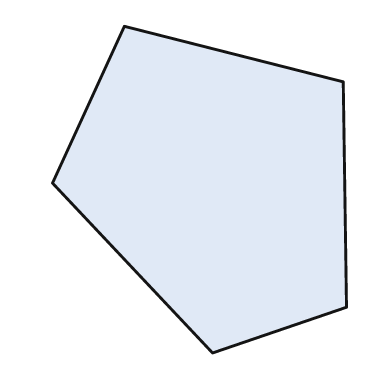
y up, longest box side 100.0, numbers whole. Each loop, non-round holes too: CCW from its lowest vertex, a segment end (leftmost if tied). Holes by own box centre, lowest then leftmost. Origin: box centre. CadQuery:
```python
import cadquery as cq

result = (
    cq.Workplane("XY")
    .moveTo(4.0, -50.0)
    .lineTo(45.0, -36.0)
    .lineTo(44.0, 33.0)
    .lineTo(-23.0, 50.0)
    .lineTo(-45.0, 2.0)
    .close()
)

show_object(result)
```